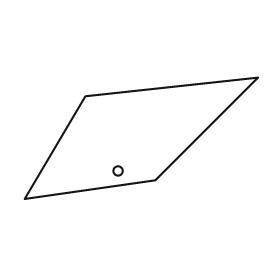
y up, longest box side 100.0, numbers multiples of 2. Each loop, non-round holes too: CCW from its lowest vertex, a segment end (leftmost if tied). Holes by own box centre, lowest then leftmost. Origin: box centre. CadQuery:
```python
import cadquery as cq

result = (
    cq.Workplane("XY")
    .moveTo(-50.0, -26.0)
    .lineTo(6.0, -18.0)
    .lineTo(50.0, 26.0)
    .lineTo(-24.0, 18.0)
    .close()
    .moveTo(-10.0, -14.0)
    .circle(2.0)
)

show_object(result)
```